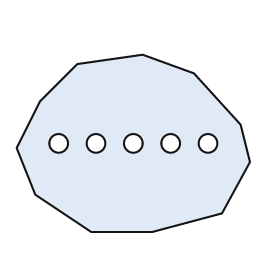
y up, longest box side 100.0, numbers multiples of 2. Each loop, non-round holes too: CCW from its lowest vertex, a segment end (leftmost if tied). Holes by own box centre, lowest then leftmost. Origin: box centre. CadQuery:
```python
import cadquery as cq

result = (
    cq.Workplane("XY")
    .moveTo(-18.0, -38.0)
    .lineTo(8.0, -38.0)
    .lineTo(38.0, -30.0)
    .lineTo(50.0, -8.0)
    .lineTo(46.0, 8.0)
    .lineTo(26.0, 30.0)
    .lineTo(4.0, 38.0)
    .lineTo(-24.0, 34.0)
    .lineTo(-40.0, 18.0)
    .lineTo(-50.0, -2.0)
    .lineTo(-42.0, -22.0)
    .close()
    .moveTo(-32.0, 0.0)
    .circle(4.0)
    .moveTo(-16.0, 0.0)
    .circle(4.0)
    .moveTo(0.0, 0.0)
    .circle(4.0)
    .moveTo(16.0, 0.0)
    .circle(4.0)
    .moveTo(32.0, 0.0)
    .circle(4.0)
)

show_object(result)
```